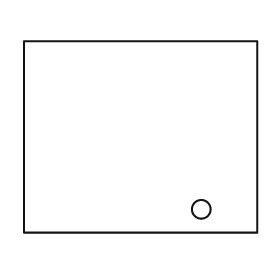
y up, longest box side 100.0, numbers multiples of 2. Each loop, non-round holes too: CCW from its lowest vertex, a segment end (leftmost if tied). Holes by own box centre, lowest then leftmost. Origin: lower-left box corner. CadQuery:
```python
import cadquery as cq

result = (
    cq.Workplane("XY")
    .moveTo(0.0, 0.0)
    .lineTo(100.0, 0.0)
    .lineTo(100.0, 82.0)
    .lineTo(0.0, 82.0)
    .close()
    .moveTo(76.0, 10.0)
    .circle(4.0)
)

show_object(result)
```